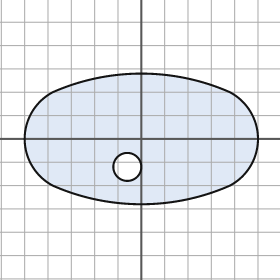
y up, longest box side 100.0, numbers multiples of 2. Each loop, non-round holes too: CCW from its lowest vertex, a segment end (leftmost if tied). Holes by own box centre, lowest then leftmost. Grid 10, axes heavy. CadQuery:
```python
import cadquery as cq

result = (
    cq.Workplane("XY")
    .moveTo(-38.0, -20.0)
    .threePointArc((0.0, -28.0), (38.0, -20.0))
    .threePointArc((50.0, 0.0), (38.0, 20.0))
    .threePointArc((0.0, 28.0), (-38.0, 20.0))
    .threePointArc((-50.0, 0.0), (-38.0, -20.0))
    .close()
    .moveTo(-6.0, -12.0)
    .circle(6.0)
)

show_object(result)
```